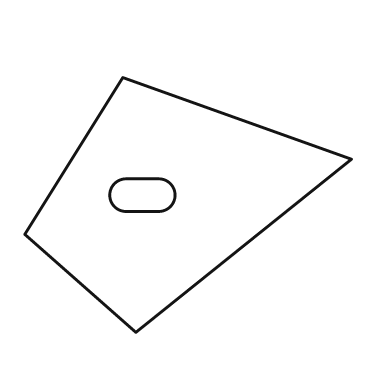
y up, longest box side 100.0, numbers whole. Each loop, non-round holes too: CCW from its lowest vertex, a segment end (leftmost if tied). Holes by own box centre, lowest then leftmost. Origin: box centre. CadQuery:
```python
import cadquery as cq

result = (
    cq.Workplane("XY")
    .moveTo(-16.0, -39.0)
    .lineTo(50.0, 14.0)
    .lineTo(-20.0, 39.0)
    .lineTo(-50.0, -9.0)
    .close()
    .moveTo(-19.0, -2.0)
    .lineTo(-9.0, -2.0)
    .threePointArc((-4.0, 3.0), (-9.0, 8.0))
    .lineTo(-19.0, 8.0)
    .threePointArc((-24.0, 3.0), (-19.0, -2.0))
    .close()
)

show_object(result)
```